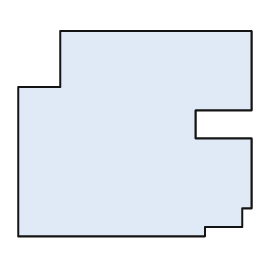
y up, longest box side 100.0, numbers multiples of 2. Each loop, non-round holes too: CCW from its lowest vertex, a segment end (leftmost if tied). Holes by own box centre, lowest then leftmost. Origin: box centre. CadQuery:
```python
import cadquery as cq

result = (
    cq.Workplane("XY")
    .moveTo(-50.0, -44.0)
    .lineTo(30.0, -44.0)
    .lineTo(30.0, -40.0)
    .lineTo(46.0, -40.0)
    .lineTo(46.0, -32.0)
    .lineTo(50.0, -32.0)
    .lineTo(50.0, -2.0)
    .lineTo(26.0, -2.0)
    .lineTo(26.0, 10.0)
    .lineTo(50.0, 10.0)
    .lineTo(50.0, 44.0)
    .lineTo(-32.0, 44.0)
    .lineTo(-32.0, 20.0)
    .lineTo(-50.0, 20.0)
    .close()
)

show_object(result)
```